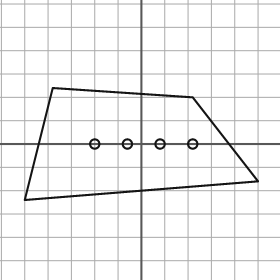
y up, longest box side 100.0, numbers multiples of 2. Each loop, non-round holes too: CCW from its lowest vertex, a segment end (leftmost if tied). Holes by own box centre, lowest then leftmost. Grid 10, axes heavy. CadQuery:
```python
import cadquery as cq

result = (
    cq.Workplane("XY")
    .moveTo(-50.0, -24.0)
    .lineTo(50.0, -16.0)
    .lineTo(22.0, 20.0)
    .lineTo(-38.0, 24.0)
    .close()
    .moveTo(-20.0, 0.0)
    .circle(2.0)
    .moveTo(-6.0, 0.0)
    .circle(2.0)
    .moveTo(8.0, 0.0)
    .circle(2.0)
    .moveTo(22.0, 0.0)
    .circle(2.0)
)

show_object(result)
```